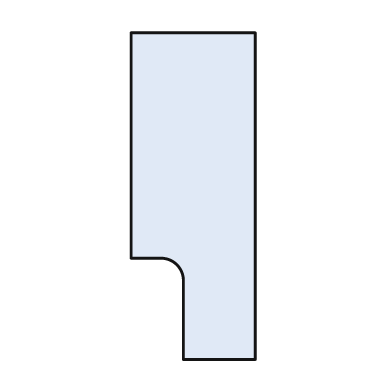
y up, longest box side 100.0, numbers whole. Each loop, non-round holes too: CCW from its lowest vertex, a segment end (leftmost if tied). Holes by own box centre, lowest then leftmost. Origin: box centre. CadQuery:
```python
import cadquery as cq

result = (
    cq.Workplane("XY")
    .moveTo(-3.0, -50.0)
    .lineTo(19.0, -50.0)
    .lineTo(19.0, 50.0)
    .lineTo(-19.0, 50.0)
    .lineTo(-19.0, -19.0)
    .lineTo(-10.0, -19.0)
    .threePointArc((-5.0, -21.0), (-3.0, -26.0))
    .close()
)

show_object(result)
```